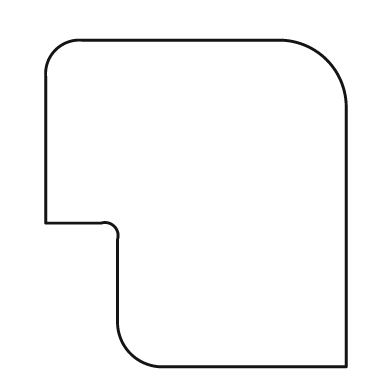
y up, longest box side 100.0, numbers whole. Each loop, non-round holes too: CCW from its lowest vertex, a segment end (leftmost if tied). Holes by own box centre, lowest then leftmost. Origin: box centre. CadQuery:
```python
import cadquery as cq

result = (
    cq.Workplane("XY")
    .moveTo(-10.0, -50.0)
    .lineTo(46.0, -50.0)
    .lineTo(46.0, 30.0)
    .threePointArc((40.0, 44.0), (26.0, 50.0))
    .lineTo(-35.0, 50.0)
    .threePointArc((-43.0, 47.0), (-46.0, 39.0))
    .lineTo(-46.0, -6.0)
    .lineTo(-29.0, -6.0)
    .threePointArc((-25.0, -7.0), (-24.0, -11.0))
    .lineTo(-24.0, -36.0)
    .threePointArc((-20.0, -46.0), (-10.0, -50.0))
    .close()
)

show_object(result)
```